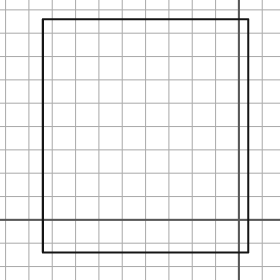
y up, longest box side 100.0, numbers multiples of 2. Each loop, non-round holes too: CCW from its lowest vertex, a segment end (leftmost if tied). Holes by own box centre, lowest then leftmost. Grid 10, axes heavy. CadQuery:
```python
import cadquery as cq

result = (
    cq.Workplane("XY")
    .moveTo(-84.0, -14.0)
    .lineTo(4.0, -14.0)
    .lineTo(4.0, 86.0)
    .lineTo(-84.0, 86.0)
    .close()
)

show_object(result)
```